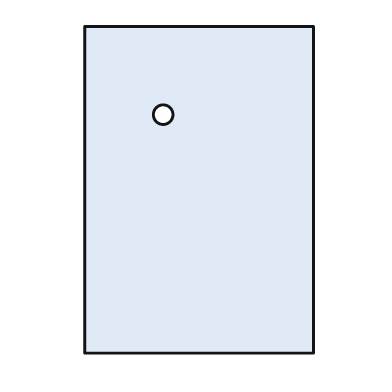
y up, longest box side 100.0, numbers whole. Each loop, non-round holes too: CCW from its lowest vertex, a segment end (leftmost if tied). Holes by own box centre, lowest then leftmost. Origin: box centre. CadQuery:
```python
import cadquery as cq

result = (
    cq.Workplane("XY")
    .moveTo(-35.0, -50.0)
    .lineTo(35.0, -50.0)
    .lineTo(35.0, 50.0)
    .lineTo(-35.0, 50.0)
    .close()
    .moveTo(-11.0, 23.0)
    .circle(3.0)
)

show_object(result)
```